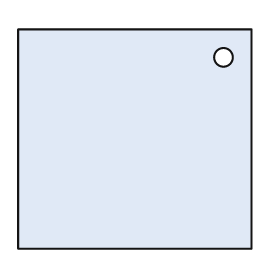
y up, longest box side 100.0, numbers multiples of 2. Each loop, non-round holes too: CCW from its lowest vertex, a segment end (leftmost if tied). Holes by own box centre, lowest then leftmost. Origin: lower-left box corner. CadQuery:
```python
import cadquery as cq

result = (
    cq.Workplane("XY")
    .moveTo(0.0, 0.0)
    .lineTo(100.0, 0.0)
    .lineTo(100.0, 94.0)
    .lineTo(0.0, 94.0)
    .close()
    .moveTo(88.0, 82.0)
    .circle(4.0)
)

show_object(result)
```